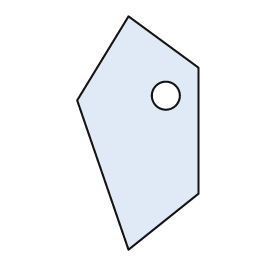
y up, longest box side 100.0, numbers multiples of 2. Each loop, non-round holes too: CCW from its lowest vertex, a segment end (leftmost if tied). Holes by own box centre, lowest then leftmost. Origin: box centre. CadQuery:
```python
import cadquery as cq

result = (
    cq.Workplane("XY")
    .moveTo(-4.0, -50.0)
    .lineTo(26.0, -26.0)
    .lineTo(26.0, 28.0)
    .lineTo(-4.0, 50.0)
    .lineTo(-26.0, 14.0)
    .close()
    .moveTo(12.0, 16.0)
    .circle(6.0)
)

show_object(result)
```